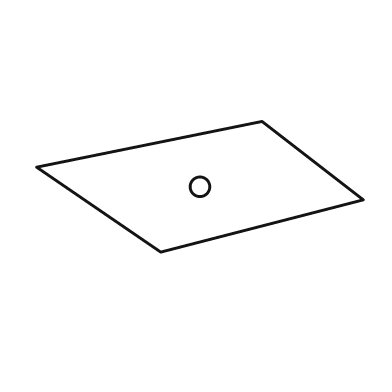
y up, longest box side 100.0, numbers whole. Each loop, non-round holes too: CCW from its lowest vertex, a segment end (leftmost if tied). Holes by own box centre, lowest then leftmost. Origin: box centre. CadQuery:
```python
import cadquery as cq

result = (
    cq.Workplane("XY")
    .moveTo(-12.0, -20.0)
    .lineTo(50.0, -4.0)
    .lineTo(19.0, 20.0)
    .lineTo(-50.0, 6.0)
    .close()
    .moveTo(0.0, 0.0)
    .circle(3.0)
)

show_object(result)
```